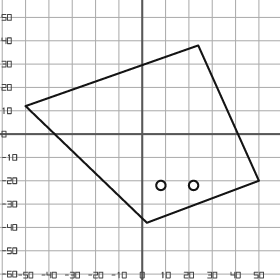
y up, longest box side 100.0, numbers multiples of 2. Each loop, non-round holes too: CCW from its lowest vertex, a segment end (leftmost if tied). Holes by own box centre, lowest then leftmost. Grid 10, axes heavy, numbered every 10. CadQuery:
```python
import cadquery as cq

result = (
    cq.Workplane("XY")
    .moveTo(2.0, -38.0)
    .lineTo(50.0, -20.0)
    .lineTo(24.0, 38.0)
    .lineTo(-50.0, 12.0)
    .close()
    .moveTo(8.0, -22.0)
    .circle(2.0)
    .moveTo(22.0, -22.0)
    .circle(2.0)
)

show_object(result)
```